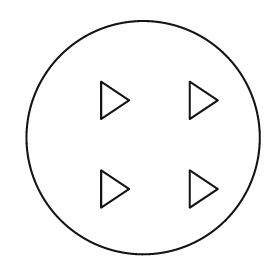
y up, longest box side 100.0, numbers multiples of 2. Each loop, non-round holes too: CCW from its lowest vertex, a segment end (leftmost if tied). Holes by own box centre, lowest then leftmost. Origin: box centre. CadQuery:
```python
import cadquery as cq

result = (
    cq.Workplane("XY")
    .moveTo(0.0, 0.0)
    .circle(50.0)
    .moveTo(-18.0, -30.0)
    .lineTo(-6.0, -22.0)
    .lineTo(-18.0, -14.0)
    .close()
    .moveTo(20.0, -30.0)
    .lineTo(32.0, -22.0)
    .lineTo(20.0, -14.0)
    .close()
    .moveTo(-18.0, 8.0)
    .lineTo(-6.0, 16.0)
    .lineTo(-18.0, 24.0)
    .close()
    .moveTo(20.0, 8.0)
    .lineTo(32.0, 16.0)
    .lineTo(20.0, 24.0)
    .close()
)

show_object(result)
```